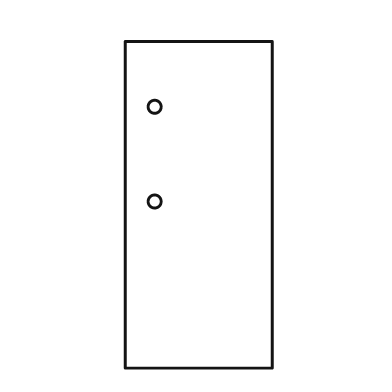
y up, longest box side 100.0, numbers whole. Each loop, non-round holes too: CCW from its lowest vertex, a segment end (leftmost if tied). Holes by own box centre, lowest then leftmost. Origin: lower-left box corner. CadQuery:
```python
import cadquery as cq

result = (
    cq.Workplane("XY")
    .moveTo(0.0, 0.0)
    .lineTo(45.0, 0.0)
    .lineTo(45.0, 100.0)
    .lineTo(0.0, 100.0)
    .close()
    .moveTo(9.0, 51.0)
    .circle(2.0)
    .moveTo(9.0, 80.0)
    .circle(2.0)
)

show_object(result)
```